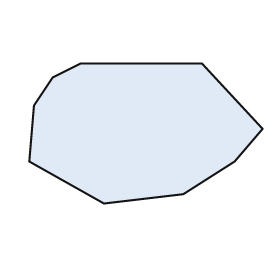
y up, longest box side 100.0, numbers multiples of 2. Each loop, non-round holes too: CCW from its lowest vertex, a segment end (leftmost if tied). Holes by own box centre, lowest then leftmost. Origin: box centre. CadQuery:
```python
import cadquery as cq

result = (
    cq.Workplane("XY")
    .moveTo(-18.0, -30.0)
    .lineTo(16.0, -26.0)
    .lineTo(38.0, -12.0)
    .lineTo(50.0, 2.0)
    .lineTo(24.0, 30.0)
    .lineTo(-28.0, 30.0)
    .lineTo(-40.0, 24.0)
    .lineTo(-48.0, 12.0)
    .lineTo(-50.0, -12.0)
    .close()
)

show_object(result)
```